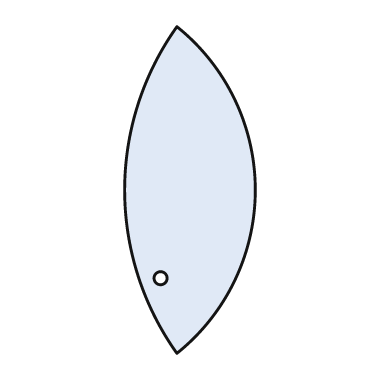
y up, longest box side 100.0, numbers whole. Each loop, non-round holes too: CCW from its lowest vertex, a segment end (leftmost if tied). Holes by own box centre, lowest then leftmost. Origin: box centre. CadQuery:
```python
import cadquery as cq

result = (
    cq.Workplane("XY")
    .moveTo(-4.0, -50.0)
    .threePointArc((20.0, 0.0), (-4.0, 50.0))
    .threePointArc((-20.0, 0.0), (-4.0, -50.0))
    .close()
    .moveTo(-9.0, -27.0)
    .circle(2.0)
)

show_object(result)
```